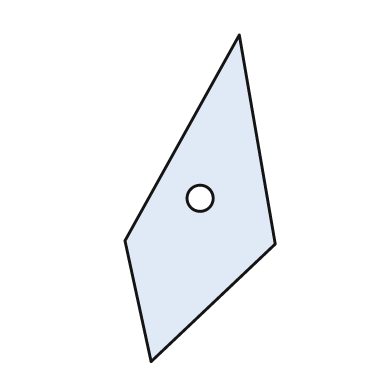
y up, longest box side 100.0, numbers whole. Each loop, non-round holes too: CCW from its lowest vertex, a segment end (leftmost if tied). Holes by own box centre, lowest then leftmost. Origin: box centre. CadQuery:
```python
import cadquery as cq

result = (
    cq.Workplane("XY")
    .moveTo(-15.0, -50.0)
    .lineTo(23.0, -14.0)
    .lineTo(12.0, 50.0)
    .lineTo(-23.0, -13.0)
    .close()
    .moveTo(0.0, 0.0)
    .circle(4.0)
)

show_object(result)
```